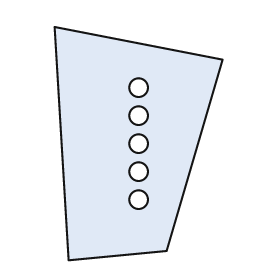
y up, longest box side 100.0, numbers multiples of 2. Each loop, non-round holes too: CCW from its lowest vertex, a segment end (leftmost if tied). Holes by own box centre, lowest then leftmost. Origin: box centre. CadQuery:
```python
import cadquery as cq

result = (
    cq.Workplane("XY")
    .moveTo(-30.0, -50.0)
    .lineTo(12.0, -46.0)
    .lineTo(36.0, 36.0)
    .lineTo(-36.0, 50.0)
    .close()
    .moveTo(0.0, -24.0)
    .circle(4.0)
    .moveTo(0.0, -12.0)
    .circle(4.0)
    .moveTo(0.0, 0.0)
    .circle(4.0)
    .moveTo(0.0, 12.0)
    .circle(4.0)
    .moveTo(0.0, 24.0)
    .circle(4.0)
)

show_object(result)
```